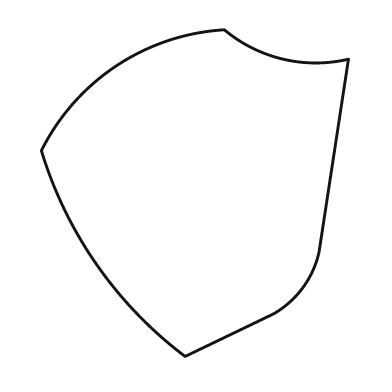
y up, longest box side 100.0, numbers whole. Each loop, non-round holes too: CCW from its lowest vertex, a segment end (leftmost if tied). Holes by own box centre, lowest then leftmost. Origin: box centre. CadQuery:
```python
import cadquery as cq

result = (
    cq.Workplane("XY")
    .moveTo(-3.0, -50.0)
    .lineTo(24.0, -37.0)
    .threePointArc((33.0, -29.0), (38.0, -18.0))
    .lineTo(47.0, 41.0)
    .threePointArc((27.0, 41.0), (9.0, 50.0))
    .threePointArc((-24.0, 39.0), (-47.0, 13.0))
    .threePointArc((-30.0, -22.0), (-3.0, -50.0))
    .close()
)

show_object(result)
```